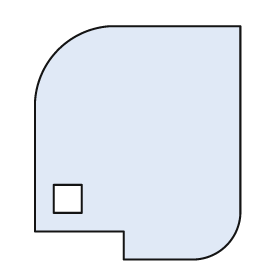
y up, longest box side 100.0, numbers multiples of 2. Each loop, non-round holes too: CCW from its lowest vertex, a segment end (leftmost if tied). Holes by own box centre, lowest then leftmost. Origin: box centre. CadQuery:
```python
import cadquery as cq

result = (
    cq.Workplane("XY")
    .moveTo(-6.0, -50.0)
    .lineTo(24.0, -50.0)
    .threePointArc((38.0, -44.0), (44.0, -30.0))
    .lineTo(44.0, 50.0)
    .lineTo(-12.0, 50.0)
    .threePointArc((-34.0, 40.0), (-44.0, 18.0))
    .lineTo(-44.0, -38.0)
    .lineTo(-6.0, -38.0)
    .close()
    .moveTo(-36.0, -30.0)
    .lineTo(-24.0, -30.0)
    .lineTo(-24.0, -18.0)
    .lineTo(-36.0, -18.0)
    .close()
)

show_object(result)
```